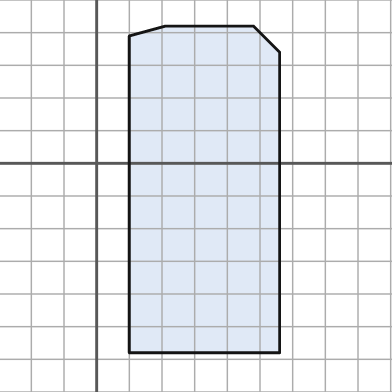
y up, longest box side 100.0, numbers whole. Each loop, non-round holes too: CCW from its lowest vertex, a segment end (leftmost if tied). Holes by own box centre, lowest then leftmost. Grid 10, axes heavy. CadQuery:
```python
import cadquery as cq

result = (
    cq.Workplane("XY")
    .moveTo(10.0, -58.0)
    .lineTo(56.0, -58.0)
    .lineTo(56.0, 34.0)
    .lineTo(48.0, 42.0)
    .lineTo(21.0, 42.0)
    .lineTo(10.0, 39.0)
    .close()
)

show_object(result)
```